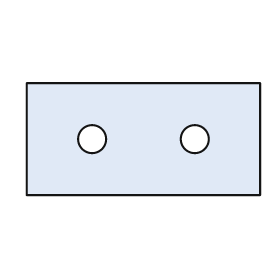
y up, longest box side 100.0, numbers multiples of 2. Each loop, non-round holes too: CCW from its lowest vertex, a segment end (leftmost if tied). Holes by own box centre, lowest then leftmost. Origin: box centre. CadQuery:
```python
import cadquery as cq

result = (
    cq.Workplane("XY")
    .moveTo(-50.0, -24.0)
    .lineTo(50.0, -24.0)
    .lineTo(50.0, 24.0)
    .lineTo(-50.0, 24.0)
    .close()
    .moveTo(-22.0, 0.0)
    .circle(6.0)
    .moveTo(22.0, 0.0)
    .circle(6.0)
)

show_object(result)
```